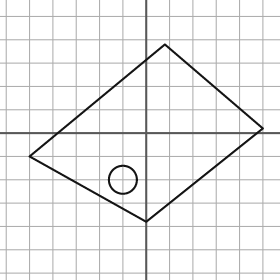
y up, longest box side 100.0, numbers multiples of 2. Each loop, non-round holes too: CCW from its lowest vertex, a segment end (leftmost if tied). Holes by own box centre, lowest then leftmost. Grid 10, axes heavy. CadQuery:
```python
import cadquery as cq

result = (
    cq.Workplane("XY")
    .moveTo(0.0, -38.0)
    .lineTo(50.0, 2.0)
    .lineTo(8.0, 38.0)
    .lineTo(-50.0, -10.0)
    .close()
    .moveTo(-10.0, -20.0)
    .circle(6.0)
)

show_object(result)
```